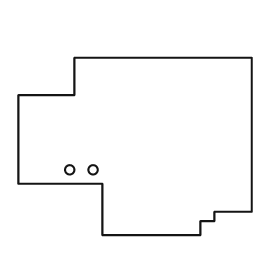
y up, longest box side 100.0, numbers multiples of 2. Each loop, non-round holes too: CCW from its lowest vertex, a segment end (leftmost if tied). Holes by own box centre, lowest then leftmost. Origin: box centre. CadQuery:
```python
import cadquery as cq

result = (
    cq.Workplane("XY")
    .moveTo(-14.0, -38.0)
    .lineTo(28.0, -38.0)
    .lineTo(28.0, -32.0)
    .lineTo(34.0, -32.0)
    .lineTo(34.0, -28.0)
    .lineTo(50.0, -28.0)
    .lineTo(50.0, 38.0)
    .lineTo(-26.0, 38.0)
    .lineTo(-26.0, 22.0)
    .lineTo(-50.0, 22.0)
    .lineTo(-50.0, -16.0)
    .lineTo(-14.0, -16.0)
    .close()
    .moveTo(-28.0, -10.0)
    .circle(2.0)
    .moveTo(-18.0, -10.0)
    .circle(2.0)
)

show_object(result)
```